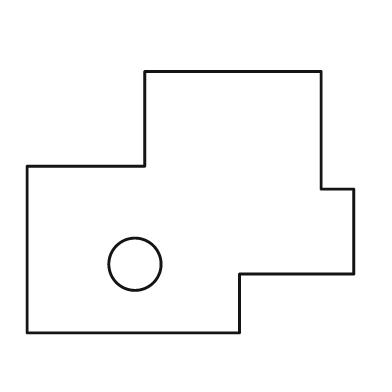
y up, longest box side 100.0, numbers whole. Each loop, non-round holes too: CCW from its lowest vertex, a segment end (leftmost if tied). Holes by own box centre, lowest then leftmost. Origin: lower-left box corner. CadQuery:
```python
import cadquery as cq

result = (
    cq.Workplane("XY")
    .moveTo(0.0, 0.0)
    .lineTo(65.0, 0.0)
    .lineTo(65.0, 18.0)
    .lineTo(100.0, 18.0)
    .lineTo(100.0, 44.0)
    .lineTo(90.0, 44.0)
    .lineTo(90.0, 80.0)
    .lineTo(36.0, 80.0)
    .lineTo(36.0, 51.0)
    .lineTo(0.0, 51.0)
    .close()
    .moveTo(33.0, 21.0)
    .circle(8.0)
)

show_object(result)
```